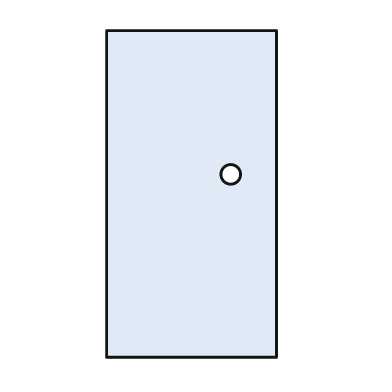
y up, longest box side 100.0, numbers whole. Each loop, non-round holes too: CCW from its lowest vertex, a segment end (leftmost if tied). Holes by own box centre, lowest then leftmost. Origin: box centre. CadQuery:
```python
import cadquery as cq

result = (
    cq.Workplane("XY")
    .moveTo(-26.0, -50.0)
    .lineTo(26.0, -50.0)
    .lineTo(26.0, 50.0)
    .lineTo(-26.0, 50.0)
    .close()
    .moveTo(12.0, 6.0)
    .circle(3.0)
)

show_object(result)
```